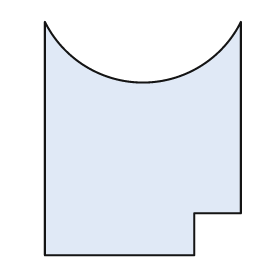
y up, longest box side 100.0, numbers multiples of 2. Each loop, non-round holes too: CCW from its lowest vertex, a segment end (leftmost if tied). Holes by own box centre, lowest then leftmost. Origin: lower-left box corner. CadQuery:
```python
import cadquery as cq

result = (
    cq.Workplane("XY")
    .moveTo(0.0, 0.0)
    .lineTo(64.0, 0.0)
    .lineTo(64.0, 18.0)
    .lineTo(84.0, 18.0)
    .lineTo(84.0, 100.0)
    .threePointArc((42.0, 74.0), (0.0, 100.0))
    .close()
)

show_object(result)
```